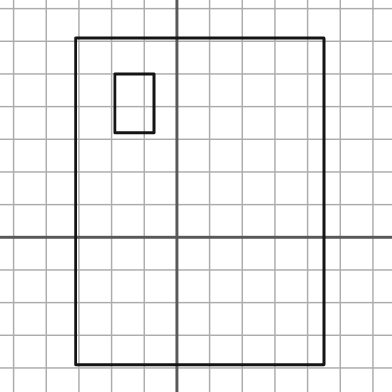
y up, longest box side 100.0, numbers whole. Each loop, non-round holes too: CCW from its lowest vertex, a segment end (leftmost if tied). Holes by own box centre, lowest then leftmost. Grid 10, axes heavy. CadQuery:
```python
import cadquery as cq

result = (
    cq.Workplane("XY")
    .moveTo(-31.0, -39.0)
    .lineTo(45.0, -39.0)
    .lineTo(45.0, 61.0)
    .lineTo(-31.0, 61.0)
    .close()
    .moveTo(-19.0, 32.0)
    .lineTo(-7.0, 32.0)
    .lineTo(-7.0, 50.0)
    .lineTo(-19.0, 50.0)
    .close()
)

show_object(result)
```